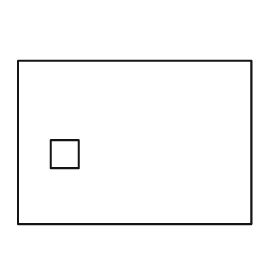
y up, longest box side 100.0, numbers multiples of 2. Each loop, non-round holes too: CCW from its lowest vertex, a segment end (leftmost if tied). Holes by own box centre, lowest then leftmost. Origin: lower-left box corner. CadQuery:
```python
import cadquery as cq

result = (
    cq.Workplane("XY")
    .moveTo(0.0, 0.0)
    .lineTo(100.0, 0.0)
    .lineTo(100.0, 70.0)
    .lineTo(0.0, 70.0)
    .close()
    .moveTo(14.0, 24.0)
    .lineTo(26.0, 24.0)
    .lineTo(26.0, 36.0)
    .lineTo(14.0, 36.0)
    .close()
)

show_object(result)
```